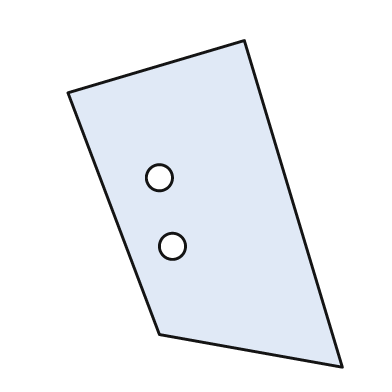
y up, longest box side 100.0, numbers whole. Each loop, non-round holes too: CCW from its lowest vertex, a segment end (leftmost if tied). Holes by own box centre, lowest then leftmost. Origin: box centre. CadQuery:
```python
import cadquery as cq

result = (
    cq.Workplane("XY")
    .moveTo(42.0, -50.0)
    .lineTo(12.0, 50.0)
    .lineTo(-42.0, 34.0)
    .lineTo(-14.0, -40.0)
    .close()
    .moveTo(-10.0, -13.0)
    .circle(4.0)
    .moveTo(-14.0, 8.0)
    .circle(4.0)
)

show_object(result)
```